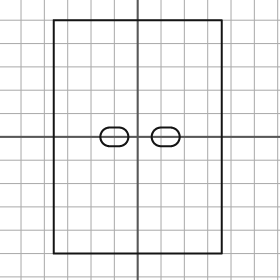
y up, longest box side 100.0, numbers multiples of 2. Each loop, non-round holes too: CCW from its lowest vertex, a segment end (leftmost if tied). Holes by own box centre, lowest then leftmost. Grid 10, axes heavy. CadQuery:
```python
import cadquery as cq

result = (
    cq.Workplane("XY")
    .moveTo(-36.0, -50.0)
    .lineTo(36.0, -50.0)
    .lineTo(36.0, 50.0)
    .lineTo(-36.0, 50.0)
    .close()
    .moveTo(-12.0, -4.0)
    .lineTo(-8.0, -4.0)
    .threePointArc((-4.0, 0.0), (-8.0, 4.0))
    .lineTo(-12.0, 4.0)
    .threePointArc((-16.0, 0.0), (-12.0, -4.0))
    .close()
    .moveTo(10.0, -4.0)
    .lineTo(14.0, -4.0)
    .threePointArc((18.0, 0.0), (14.0, 4.0))
    .lineTo(10.0, 4.0)
    .threePointArc((6.0, 0.0), (10.0, -4.0))
    .close()
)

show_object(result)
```